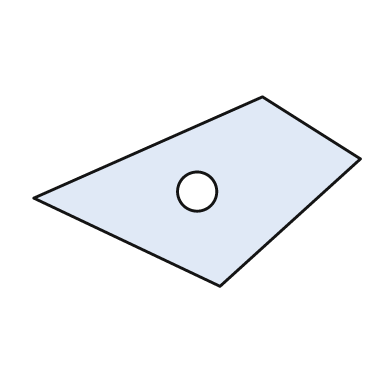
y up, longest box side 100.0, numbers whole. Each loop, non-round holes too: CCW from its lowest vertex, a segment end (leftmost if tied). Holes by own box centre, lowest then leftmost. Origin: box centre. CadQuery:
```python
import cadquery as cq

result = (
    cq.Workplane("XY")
    .moveTo(7.0, -29.0)
    .lineTo(50.0, 10.0)
    .lineTo(20.0, 29.0)
    .lineTo(-50.0, -2.0)
    .close()
    .moveTo(0.0, 0.0)
    .circle(6.0)
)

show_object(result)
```